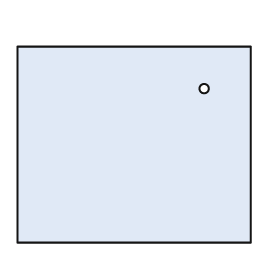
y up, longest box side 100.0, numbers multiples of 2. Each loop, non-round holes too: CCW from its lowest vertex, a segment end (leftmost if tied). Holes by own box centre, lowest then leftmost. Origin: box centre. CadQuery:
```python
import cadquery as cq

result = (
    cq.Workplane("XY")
    .moveTo(-50.0, -42.0)
    .lineTo(50.0, -42.0)
    .lineTo(50.0, 42.0)
    .lineTo(-50.0, 42.0)
    .close()
    .moveTo(30.0, 24.0)
    .circle(2.0)
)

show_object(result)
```